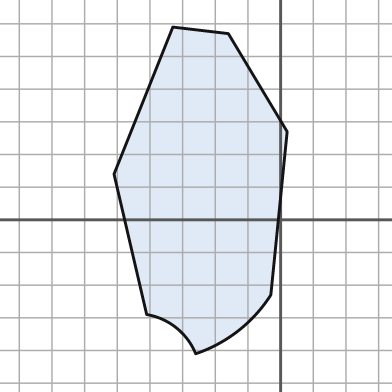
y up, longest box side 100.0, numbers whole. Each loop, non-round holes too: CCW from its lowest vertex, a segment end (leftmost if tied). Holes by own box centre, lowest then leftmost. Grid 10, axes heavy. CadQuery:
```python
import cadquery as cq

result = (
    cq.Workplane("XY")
    .moveTo(-26.0, -41.0)
    .threePointArc((-13.0, -34.0), (-3.0, -23.0))
    .lineTo(2.0, 27.0)
    .lineTo(-16.0, 57.0)
    .lineTo(-33.0, 59.0)
    .lineTo(-51.0, 14.0)
    .lineTo(-41.0, -29.0)
    .threePointArc((-32.0, -33.0), (-26.0, -41.0))
    .close()
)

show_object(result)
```